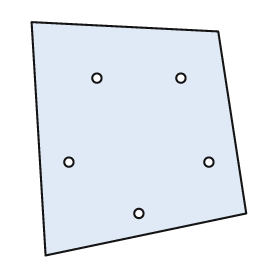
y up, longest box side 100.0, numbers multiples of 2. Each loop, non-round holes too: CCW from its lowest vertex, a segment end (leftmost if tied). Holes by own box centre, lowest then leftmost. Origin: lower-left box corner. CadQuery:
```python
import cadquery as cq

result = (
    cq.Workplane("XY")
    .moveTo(6.0, 0.0)
    .lineTo(92.0, 18.0)
    .lineTo(80.0, 96.0)
    .lineTo(0.0, 100.0)
    .close()
    .moveTo(46.0, 18.0)
    .circle(2.0)
    .moveTo(16.0, 40.0)
    .circle(2.0)
    .moveTo(76.0, 40.0)
    .circle(2.0)
    .moveTo(28.0, 76.0)
    .circle(2.0)
    .moveTo(64.0, 76.0)
    .circle(2.0)
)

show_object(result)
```